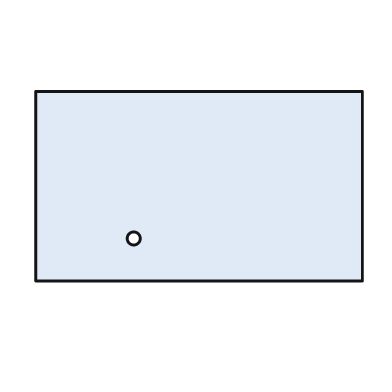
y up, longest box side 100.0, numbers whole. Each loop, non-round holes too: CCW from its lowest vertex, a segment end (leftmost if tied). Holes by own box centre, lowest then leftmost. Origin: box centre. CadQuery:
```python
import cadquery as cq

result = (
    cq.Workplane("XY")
    .moveTo(-50.0, -29.0)
    .lineTo(50.0, -29.0)
    .lineTo(50.0, 29.0)
    .lineTo(-50.0, 29.0)
    .close()
    .moveTo(-20.0, -16.0)
    .circle(2.0)
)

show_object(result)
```